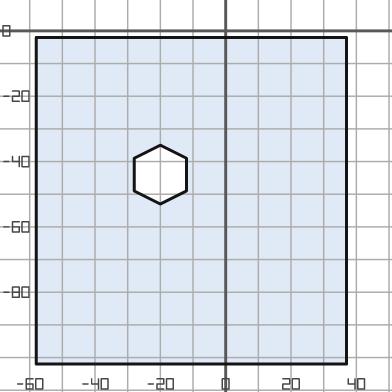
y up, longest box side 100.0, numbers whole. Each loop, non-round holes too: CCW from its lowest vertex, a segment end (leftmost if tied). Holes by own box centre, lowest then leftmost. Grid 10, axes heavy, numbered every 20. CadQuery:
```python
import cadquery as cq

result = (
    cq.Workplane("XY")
    .moveTo(-58.0, -102.0)
    .lineTo(37.0, -102.0)
    .lineTo(37.0, -2.0)
    .lineTo(-58.0, -2.0)
    .close()
    .moveTo(-20.0, -53.0)
    .lineTo(-12.0, -49.0)
    .lineTo(-12.0, -39.0)
    .lineTo(-20.0, -35.0)
    .lineTo(-28.0, -39.0)
    .lineTo(-28.0, -49.0)
    .close()
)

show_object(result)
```